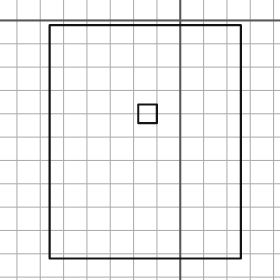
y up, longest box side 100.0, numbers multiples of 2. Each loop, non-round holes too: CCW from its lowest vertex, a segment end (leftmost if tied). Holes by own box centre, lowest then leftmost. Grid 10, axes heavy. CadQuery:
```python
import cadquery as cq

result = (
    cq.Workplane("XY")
    .moveTo(-56.0, -102.0)
    .lineTo(26.0, -102.0)
    .lineTo(26.0, -2.0)
    .lineTo(-56.0, -2.0)
    .close()
    .moveTo(-18.0, -44.0)
    .lineTo(-10.0, -44.0)
    .lineTo(-10.0, -36.0)
    .lineTo(-18.0, -36.0)
    .close()
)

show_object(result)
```